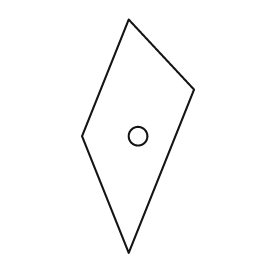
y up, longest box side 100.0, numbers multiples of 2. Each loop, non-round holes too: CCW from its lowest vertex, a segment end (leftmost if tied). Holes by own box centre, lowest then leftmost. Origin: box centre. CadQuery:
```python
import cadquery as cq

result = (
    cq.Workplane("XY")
    .moveTo(-4.0, -50.0)
    .lineTo(24.0, 20.0)
    .lineTo(-4.0, 50.0)
    .lineTo(-24.0, 0.0)
    .close()
    .moveTo(0.0, 0.0)
    .circle(4.0)
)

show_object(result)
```